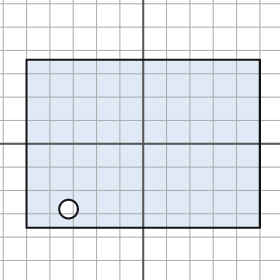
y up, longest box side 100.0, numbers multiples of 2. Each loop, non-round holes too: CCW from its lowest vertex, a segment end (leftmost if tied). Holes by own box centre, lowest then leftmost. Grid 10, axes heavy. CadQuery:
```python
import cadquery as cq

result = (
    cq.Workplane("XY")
    .moveTo(-50.0, -36.0)
    .lineTo(50.0, -36.0)
    .lineTo(50.0, 36.0)
    .lineTo(-50.0, 36.0)
    .close()
    .moveTo(-32.0, -28.0)
    .circle(4.0)
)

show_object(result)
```